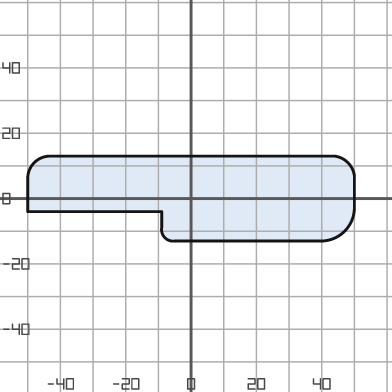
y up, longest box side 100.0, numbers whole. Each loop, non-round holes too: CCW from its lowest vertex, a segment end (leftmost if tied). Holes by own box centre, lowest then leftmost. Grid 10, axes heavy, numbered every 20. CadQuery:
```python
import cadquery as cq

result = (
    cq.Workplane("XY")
    .moveTo(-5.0, -13.0)
    .lineTo(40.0, -13.0)
    .threePointArc((47.0, -10.0), (50.0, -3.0))
    .lineTo(50.0, 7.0)
    .threePointArc((48.0, 11.0), (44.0, 13.0))
    .lineTo(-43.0, 13.0)
    .threePointArc((-48.0, 11.0), (-50.0, 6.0))
    .lineTo(-50.0, -4.0)
    .lineTo(-9.0, -4.0)
    .lineTo(-9.0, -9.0)
    .threePointArc((-8.0, -12.0), (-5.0, -13.0))
    .close()
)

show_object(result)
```